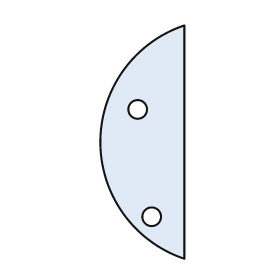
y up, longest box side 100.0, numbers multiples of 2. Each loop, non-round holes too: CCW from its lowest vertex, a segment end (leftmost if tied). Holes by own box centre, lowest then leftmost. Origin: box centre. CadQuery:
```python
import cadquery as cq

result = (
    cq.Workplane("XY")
    .moveTo(18.0, -50.0)
    .lineTo(18.0, 50.0)
    .threePointArc((-18.0, 0.0), (18.0, -50.0))
    .close()
    .moveTo(4.0, -32.0)
    .circle(4.0)
    .moveTo(-2.0, 14.0)
    .circle(4.0)
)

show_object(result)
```